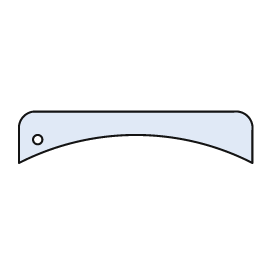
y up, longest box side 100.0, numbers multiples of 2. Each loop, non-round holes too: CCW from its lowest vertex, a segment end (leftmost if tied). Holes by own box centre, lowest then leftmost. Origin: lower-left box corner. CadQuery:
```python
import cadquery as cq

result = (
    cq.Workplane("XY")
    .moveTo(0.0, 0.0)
    .threePointArc((50.0, 12.0), (100.0, 0.0))
    .lineTo(100.0, 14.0)
    .threePointArc((98.0, 20.0), (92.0, 22.0))
    .lineTo(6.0, 22.0)
    .threePointArc((2.0, 20.0), (0.0, 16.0))
    .close()
    .moveTo(8.0, 10.0)
    .circle(2.0)
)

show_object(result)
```